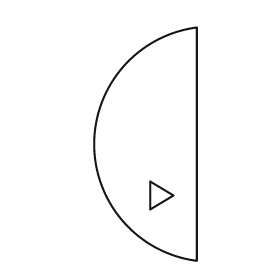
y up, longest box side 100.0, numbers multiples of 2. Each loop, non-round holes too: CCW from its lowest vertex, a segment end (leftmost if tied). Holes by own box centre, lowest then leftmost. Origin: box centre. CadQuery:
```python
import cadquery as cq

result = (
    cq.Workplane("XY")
    .moveTo(22.0, -50.0)
    .lineTo(22.0, 50.0)
    .threePointArc((-22.0, 0.0), (22.0, -50.0))
    .close()
    .moveTo(2.0, -28.0)
    .lineTo(12.0, -22.0)
    .lineTo(2.0, -16.0)
    .close()
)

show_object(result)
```